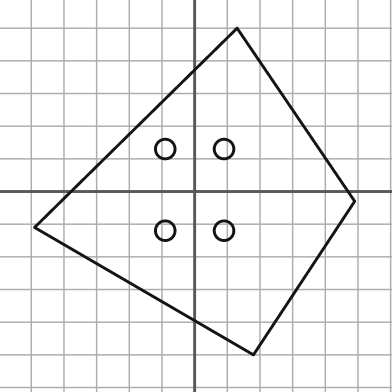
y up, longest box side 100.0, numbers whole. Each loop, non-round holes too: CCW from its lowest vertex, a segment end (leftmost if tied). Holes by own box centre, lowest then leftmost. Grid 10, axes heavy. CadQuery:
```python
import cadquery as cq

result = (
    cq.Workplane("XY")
    .moveTo(18.0, -50.0)
    .lineTo(49.0, -3.0)
    .lineTo(13.0, 50.0)
    .lineTo(-49.0, -11.0)
    .close()
    .moveTo(-9.0, -12.0)
    .circle(3.0)
    .moveTo(9.0, -12.0)
    .circle(3.0)
    .moveTo(-9.0, 13.0)
    .circle(3.0)
    .moveTo(9.0, 13.0)
    .circle(3.0)
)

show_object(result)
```